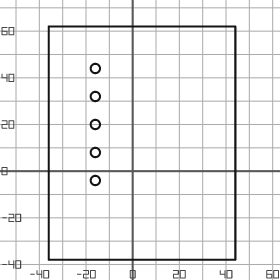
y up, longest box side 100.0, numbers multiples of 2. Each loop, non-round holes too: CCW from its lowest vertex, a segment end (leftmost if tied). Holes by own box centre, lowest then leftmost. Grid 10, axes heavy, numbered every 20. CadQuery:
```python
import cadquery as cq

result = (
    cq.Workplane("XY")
    .moveTo(-36.0, -38.0)
    .lineTo(44.0, -38.0)
    .lineTo(44.0, 62.0)
    .lineTo(-36.0, 62.0)
    .close()
    .moveTo(-16.0, -4.0)
    .circle(2.0)
    .moveTo(-16.0, 8.0)
    .circle(2.0)
    .moveTo(-16.0, 20.0)
    .circle(2.0)
    .moveTo(-16.0, 32.0)
    .circle(2.0)
    .moveTo(-16.0, 44.0)
    .circle(2.0)
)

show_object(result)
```